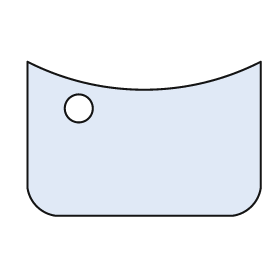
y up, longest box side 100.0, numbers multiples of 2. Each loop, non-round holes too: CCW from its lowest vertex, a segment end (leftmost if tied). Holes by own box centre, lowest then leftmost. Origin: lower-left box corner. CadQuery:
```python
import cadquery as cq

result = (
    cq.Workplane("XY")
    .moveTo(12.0, 0.0)
    .lineTo(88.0, 0.0)
    .threePointArc((96.0, 4.0), (100.0, 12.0))
    .lineTo(100.0, 66.0)
    .threePointArc((50.0, 54.0), (0.0, 66.0))
    .lineTo(0.0, 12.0)
    .threePointArc((4.0, 4.0), (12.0, 0.0))
    .close()
    .moveTo(22.0, 46.0)
    .circle(6.0)
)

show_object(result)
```